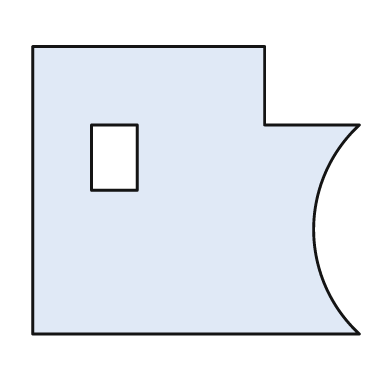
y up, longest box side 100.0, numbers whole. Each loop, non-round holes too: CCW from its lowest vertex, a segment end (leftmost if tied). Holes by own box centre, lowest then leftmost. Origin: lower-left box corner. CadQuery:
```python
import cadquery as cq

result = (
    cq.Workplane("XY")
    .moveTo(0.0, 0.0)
    .lineTo(100.0, 0.0)
    .threePointArc((86.0, 32.0), (100.0, 64.0))
    .lineTo(71.0, 64.0)
    .lineTo(71.0, 88.0)
    .lineTo(0.0, 88.0)
    .close()
    .moveTo(18.0, 44.0)
    .lineTo(32.0, 44.0)
    .lineTo(32.0, 64.0)
    .lineTo(18.0, 64.0)
    .close()
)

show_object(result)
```